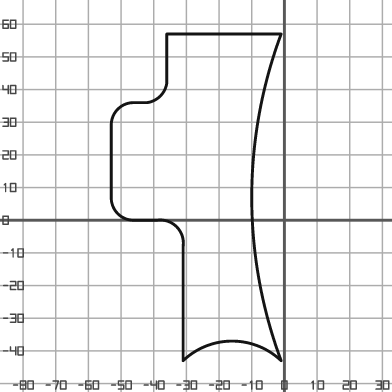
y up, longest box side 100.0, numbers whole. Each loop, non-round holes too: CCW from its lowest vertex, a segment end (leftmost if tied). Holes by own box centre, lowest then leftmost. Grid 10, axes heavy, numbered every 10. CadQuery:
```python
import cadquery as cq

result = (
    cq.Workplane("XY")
    .moveTo(-31.0, -43.0)
    .threePointArc((-16.0, -37.0), (-1.0, -43.0))
    .threePointArc((-10.0, 7.0), (-1.0, 57.0))
    .lineTo(-36.0, 57.0)
    .lineTo(-36.0, 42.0)
    .threePointArc((-38.0, 38.0), (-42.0, 36.0))
    .lineTo(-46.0, 36.0)
    .threePointArc((-51.0, 34.0), (-53.0, 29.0))
    .lineTo(-53.0, 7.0)
    .threePointArc((-51.0, 2.0), (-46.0, 0.0))
    .lineTo(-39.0, 0.0)
    .threePointArc((-33.0, -2.0), (-31.0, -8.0))
    .close()
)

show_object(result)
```